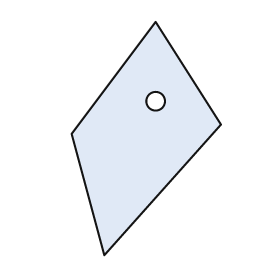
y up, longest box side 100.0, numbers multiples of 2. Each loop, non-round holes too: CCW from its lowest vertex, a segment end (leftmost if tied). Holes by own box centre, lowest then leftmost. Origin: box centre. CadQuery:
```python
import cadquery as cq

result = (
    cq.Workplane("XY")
    .moveTo(-18.0, -50.0)
    .lineTo(32.0, 6.0)
    .lineTo(4.0, 50.0)
    .lineTo(-32.0, 2.0)
    .close()
    .moveTo(4.0, 16.0)
    .circle(4.0)
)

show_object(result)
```